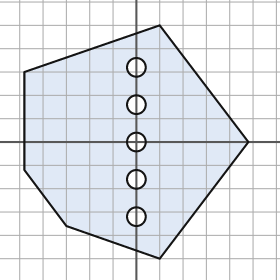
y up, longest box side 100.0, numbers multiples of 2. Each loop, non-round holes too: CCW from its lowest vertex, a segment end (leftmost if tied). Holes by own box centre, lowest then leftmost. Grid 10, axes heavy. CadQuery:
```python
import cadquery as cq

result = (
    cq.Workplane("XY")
    .moveTo(10.0, -50.0)
    .lineTo(48.0, 0.0)
    .lineTo(10.0, 50.0)
    .lineTo(-48.0, 30.0)
    .lineTo(-48.0, -12.0)
    .lineTo(-30.0, -36.0)
    .close()
    .moveTo(0.0, -32.0)
    .circle(4.0)
    .moveTo(0.0, -16.0)
    .circle(4.0)
    .moveTo(0.0, 0.0)
    .circle(4.0)
    .moveTo(0.0, 16.0)
    .circle(4.0)
    .moveTo(0.0, 32.0)
    .circle(4.0)
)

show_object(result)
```